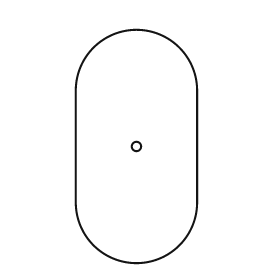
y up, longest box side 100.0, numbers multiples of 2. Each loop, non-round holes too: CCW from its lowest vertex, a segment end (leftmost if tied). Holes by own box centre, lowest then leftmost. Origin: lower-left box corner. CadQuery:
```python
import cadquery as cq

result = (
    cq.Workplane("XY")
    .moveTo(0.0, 26.0)
    .threePointArc((26.0, 0.0), (52.0, 26.0))
    .lineTo(52.0, 74.0)
    .threePointArc((26.0, 100.0), (0.0, 74.0))
    .close()
    .moveTo(26.0, 50.0)
    .circle(2.0)
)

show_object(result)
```